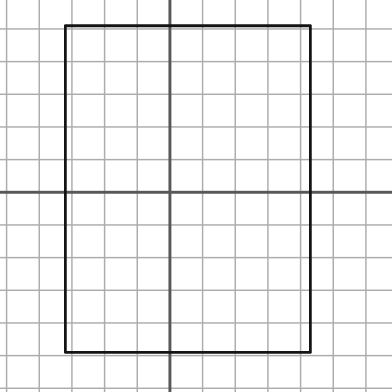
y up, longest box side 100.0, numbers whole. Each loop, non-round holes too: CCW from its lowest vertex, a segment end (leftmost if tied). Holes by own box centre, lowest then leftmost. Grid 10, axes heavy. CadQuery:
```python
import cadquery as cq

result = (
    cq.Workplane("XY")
    .moveTo(-32.0, -49.0)
    .lineTo(43.0, -49.0)
    .lineTo(43.0, 51.0)
    .lineTo(-32.0, 51.0)
    .close()
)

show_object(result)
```